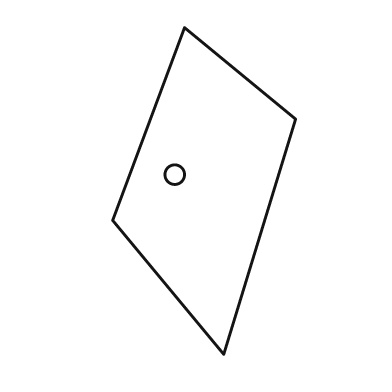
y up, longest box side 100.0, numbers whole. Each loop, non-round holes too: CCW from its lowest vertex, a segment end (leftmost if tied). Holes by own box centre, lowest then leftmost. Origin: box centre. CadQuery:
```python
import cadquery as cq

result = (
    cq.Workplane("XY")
    .moveTo(6.0, -50.0)
    .lineTo(28.0, 22.0)
    .lineTo(-6.0, 50.0)
    .lineTo(-28.0, -9.0)
    .close()
    .moveTo(-9.0, 5.0)
    .circle(3.0)
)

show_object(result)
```